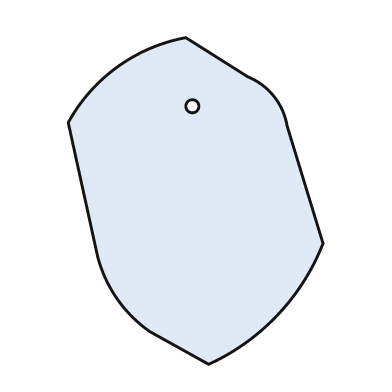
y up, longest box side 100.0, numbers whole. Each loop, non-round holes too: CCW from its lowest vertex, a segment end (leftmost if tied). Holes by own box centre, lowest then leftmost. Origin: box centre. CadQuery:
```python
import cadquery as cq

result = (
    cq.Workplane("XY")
    .moveTo(4.0, -50.0)
    .threePointArc((25.0, -35.0), (39.0, -13.0))
    .lineTo(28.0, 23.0)
    .threePointArc((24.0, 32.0), (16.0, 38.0))
    .lineTo(-3.0, 50.0)
    .threePointArc((-24.0, 41.0), (-39.0, 24.0))
    .lineTo(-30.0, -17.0)
    .threePointArc((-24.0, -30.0), (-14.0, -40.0))
    .close()
    .moveTo(-1.0, 29.0)
    .circle(2.0)
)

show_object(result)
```